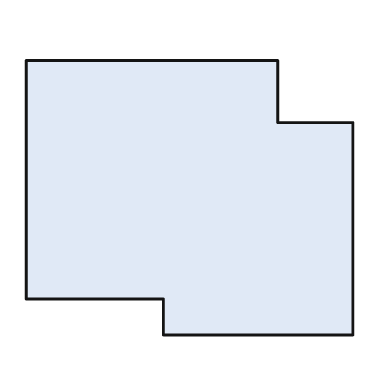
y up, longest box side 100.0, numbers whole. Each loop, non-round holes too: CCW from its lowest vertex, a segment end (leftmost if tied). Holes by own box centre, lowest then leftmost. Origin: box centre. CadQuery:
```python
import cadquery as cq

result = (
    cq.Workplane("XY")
    .moveTo(-8.0, -42.0)
    .lineTo(50.0, -42.0)
    .lineTo(50.0, 23.0)
    .lineTo(27.0, 23.0)
    .lineTo(27.0, 42.0)
    .lineTo(-50.0, 42.0)
    .lineTo(-50.0, -31.0)
    .lineTo(-8.0, -31.0)
    .close()
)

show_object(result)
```